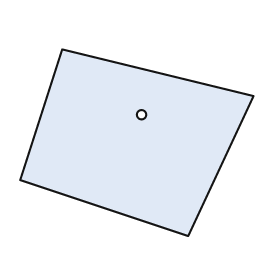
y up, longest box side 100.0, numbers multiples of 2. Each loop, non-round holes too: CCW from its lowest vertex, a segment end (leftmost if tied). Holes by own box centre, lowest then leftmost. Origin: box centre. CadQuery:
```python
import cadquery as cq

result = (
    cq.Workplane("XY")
    .moveTo(22.0, -40.0)
    .lineTo(50.0, 20.0)
    .lineTo(-32.0, 40.0)
    .lineTo(-50.0, -16.0)
    .close()
    .moveTo(2.0, 12.0)
    .circle(2.0)
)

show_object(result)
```